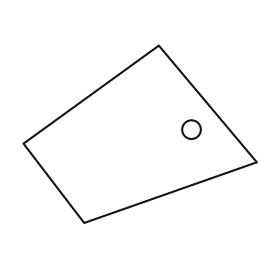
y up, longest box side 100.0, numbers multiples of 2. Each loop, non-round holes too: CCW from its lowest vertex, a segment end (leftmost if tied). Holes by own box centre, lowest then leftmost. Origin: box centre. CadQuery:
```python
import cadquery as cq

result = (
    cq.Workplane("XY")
    .moveTo(-24.0, -38.0)
    .lineTo(50.0, -12.0)
    .lineTo(8.0, 38.0)
    .lineTo(-50.0, -4.0)
    .close()
    .moveTo(22.0, 2.0)
    .circle(4.0)
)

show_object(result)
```